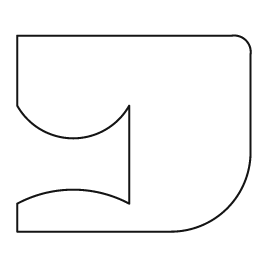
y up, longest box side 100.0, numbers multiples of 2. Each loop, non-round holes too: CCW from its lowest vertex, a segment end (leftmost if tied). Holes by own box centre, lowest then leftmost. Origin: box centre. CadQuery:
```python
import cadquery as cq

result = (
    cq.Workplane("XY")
    .moveTo(-50.0, -42.0)
    .lineTo(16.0, -42.0)
    .threePointArc((40.0, -32.0), (50.0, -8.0))
    .lineTo(50.0, 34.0)
    .threePointArc((48.0, 40.0), (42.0, 42.0))
    .lineTo(-50.0, 42.0)
    .lineTo(-50.0, 12.0)
    .threePointArc((-26.0, -2.0), (-2.0, 12.0))
    .lineTo(-2.0, -30.0)
    .threePointArc((-26.0, -24.0), (-50.0, -30.0))
    .close()
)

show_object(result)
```